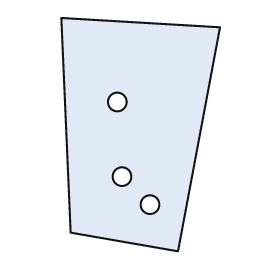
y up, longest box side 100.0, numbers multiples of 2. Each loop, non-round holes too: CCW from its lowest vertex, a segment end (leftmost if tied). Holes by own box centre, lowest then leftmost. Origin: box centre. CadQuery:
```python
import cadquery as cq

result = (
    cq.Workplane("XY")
    .moveTo(16.0, -50.0)
    .lineTo(34.0, 46.0)
    .lineTo(-34.0, 50.0)
    .lineTo(-30.0, -42.0)
    .close()
    .moveTo(4.0, -30.0)
    .circle(4.0)
    .moveTo(-8.0, -18.0)
    .circle(4.0)
    .moveTo(-10.0, 14.0)
    .circle(4.0)
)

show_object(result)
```